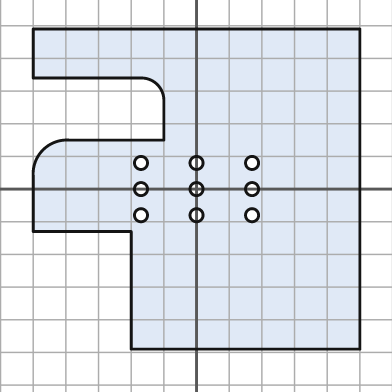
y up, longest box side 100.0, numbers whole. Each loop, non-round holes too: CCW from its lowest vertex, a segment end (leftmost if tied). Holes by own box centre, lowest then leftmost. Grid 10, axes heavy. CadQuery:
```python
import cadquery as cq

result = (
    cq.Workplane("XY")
    .moveTo(-20.0, -49.0)
    .lineTo(50.0, -49.0)
    .lineTo(50.0, 49.0)
    .lineTo(-50.0, 49.0)
    .lineTo(-50.0, 34.0)
    .lineTo(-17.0, 34.0)
    .threePointArc((-12.0, 32.0), (-10.0, 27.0))
    .lineTo(-10.0, 15.0)
    .lineTo(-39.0, 15.0)
    .threePointArc((-47.0, 12.0), (-50.0, 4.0))
    .lineTo(-50.0, -13.0)
    .lineTo(-20.0, -13.0)
    .close()
    .moveTo(-17.0, -8.0)
    .circle(2.0)
    .moveTo(0.0, -8.0)
    .circle(2.0)
    .moveTo(17.0, -8.0)
    .circle(2.0)
    .moveTo(-17.0, 0.0)
    .circle(2.0)
    .moveTo(0.0, 0.0)
    .circle(2.0)
    .moveTo(17.0, 0.0)
    .circle(2.0)
    .moveTo(-17.0, 8.0)
    .circle(2.0)
    .moveTo(0.0, 8.0)
    .circle(2.0)
    .moveTo(17.0, 8.0)
    .circle(2.0)
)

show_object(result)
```